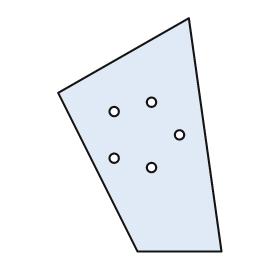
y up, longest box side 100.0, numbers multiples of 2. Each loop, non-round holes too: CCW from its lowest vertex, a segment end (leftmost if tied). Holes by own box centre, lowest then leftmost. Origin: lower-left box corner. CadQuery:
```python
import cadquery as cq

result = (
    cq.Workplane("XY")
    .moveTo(34.0, 0.0)
    .lineTo(70.0, 0.0)
    .lineTo(56.0, 100.0)
    .lineTo(0.0, 68.0)
    .close()
    .moveTo(40.0, 36.0)
    .circle(2.0)
    .moveTo(24.0, 40.0)
    .circle(2.0)
    .moveTo(52.0, 50.0)
    .circle(2.0)
    .moveTo(24.0, 60.0)
    .circle(2.0)
    .moveTo(40.0, 64.0)
    .circle(2.0)
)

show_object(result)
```